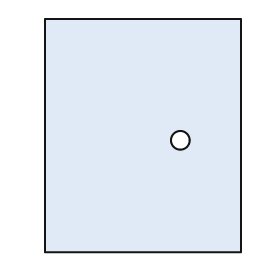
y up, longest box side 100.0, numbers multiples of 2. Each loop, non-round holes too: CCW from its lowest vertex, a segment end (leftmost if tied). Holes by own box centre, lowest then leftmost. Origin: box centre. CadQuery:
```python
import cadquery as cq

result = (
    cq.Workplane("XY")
    .moveTo(-42.0, -50.0)
    .lineTo(42.0, -50.0)
    .lineTo(42.0, 50.0)
    .lineTo(-42.0, 50.0)
    .close()
    .moveTo(16.0, -2.0)
    .circle(4.0)
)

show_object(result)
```